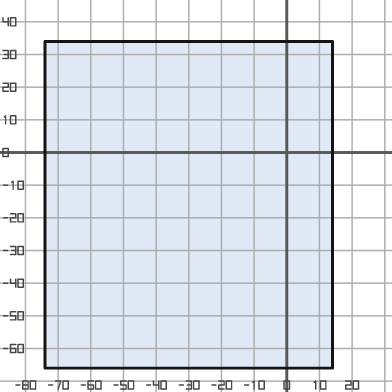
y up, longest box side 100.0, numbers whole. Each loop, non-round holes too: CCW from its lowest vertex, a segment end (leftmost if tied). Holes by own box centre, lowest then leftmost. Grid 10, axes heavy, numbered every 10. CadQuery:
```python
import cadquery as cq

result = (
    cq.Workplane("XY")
    .moveTo(-74.0, -66.0)
    .lineTo(14.0, -66.0)
    .lineTo(14.0, 34.0)
    .lineTo(-74.0, 34.0)
    .close()
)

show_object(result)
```